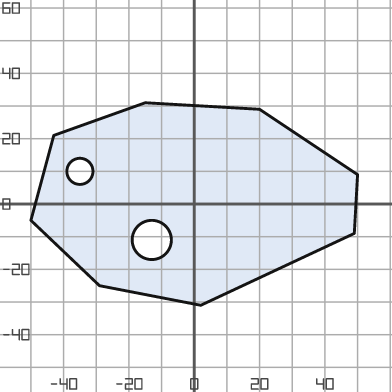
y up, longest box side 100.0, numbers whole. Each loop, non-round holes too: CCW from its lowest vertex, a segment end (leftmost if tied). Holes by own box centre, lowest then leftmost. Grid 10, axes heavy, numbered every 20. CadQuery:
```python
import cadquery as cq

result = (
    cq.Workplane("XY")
    .moveTo(2.0, -31.0)
    .lineTo(49.0, -9.0)
    .lineTo(50.0, 9.0)
    .lineTo(20.0, 29.0)
    .lineTo(-15.0, 31.0)
    .lineTo(-43.0, 21.0)
    .lineTo(-50.0, -5.0)
    .lineTo(-29.0, -25.0)
    .close()
    .moveTo(-13.0, -11.0)
    .circle(6.0)
    .moveTo(-35.0, 10.0)
    .circle(4.0)
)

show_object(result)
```